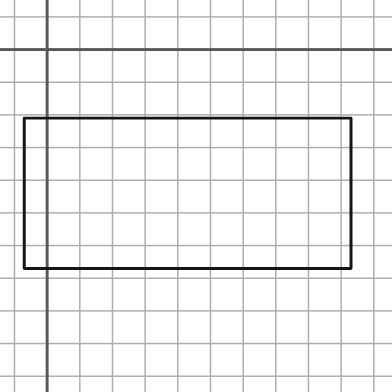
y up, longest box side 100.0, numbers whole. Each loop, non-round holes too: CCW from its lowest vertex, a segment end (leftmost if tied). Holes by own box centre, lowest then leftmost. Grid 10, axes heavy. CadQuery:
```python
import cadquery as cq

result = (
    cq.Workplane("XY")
    .moveTo(-7.0, -67.0)
    .lineTo(93.0, -67.0)
    .lineTo(93.0, -21.0)
    .lineTo(-7.0, -21.0)
    .close()
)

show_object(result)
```